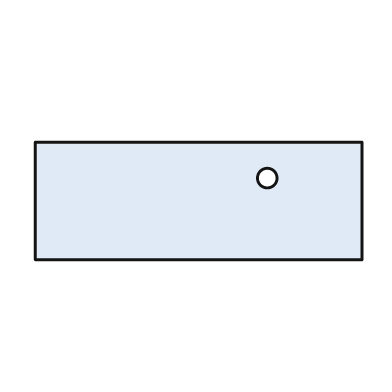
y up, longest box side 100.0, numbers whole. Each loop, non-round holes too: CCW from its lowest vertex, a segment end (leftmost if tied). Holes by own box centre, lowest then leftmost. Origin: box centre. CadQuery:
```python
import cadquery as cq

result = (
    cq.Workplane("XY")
    .moveTo(-50.0, -18.0)
    .lineTo(50.0, -18.0)
    .lineTo(50.0, 18.0)
    .lineTo(-50.0, 18.0)
    .close()
    .moveTo(21.0, 7.0)
    .circle(3.0)
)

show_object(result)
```